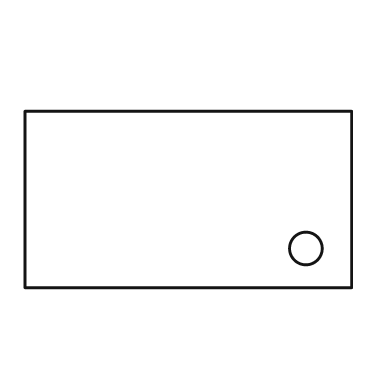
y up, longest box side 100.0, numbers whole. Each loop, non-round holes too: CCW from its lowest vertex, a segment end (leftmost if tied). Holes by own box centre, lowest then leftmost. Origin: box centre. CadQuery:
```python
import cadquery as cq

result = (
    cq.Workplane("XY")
    .moveTo(-50.0, -27.0)
    .lineTo(50.0, -27.0)
    .lineTo(50.0, 27.0)
    .lineTo(-50.0, 27.0)
    .close()
    .moveTo(36.0, -15.0)
    .circle(5.0)
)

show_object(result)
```